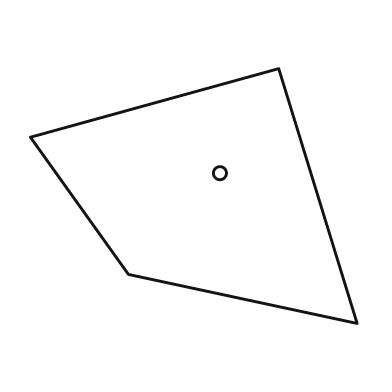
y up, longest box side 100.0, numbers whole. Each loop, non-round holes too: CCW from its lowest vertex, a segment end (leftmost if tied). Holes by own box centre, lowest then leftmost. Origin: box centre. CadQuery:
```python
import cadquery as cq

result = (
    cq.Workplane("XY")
    .moveTo(50.0, -39.0)
    .lineTo(26.0, 39.0)
    .lineTo(-50.0, 18.0)
    .lineTo(-20.0, -24.0)
    .close()
    .moveTo(8.0, 7.0)
    .circle(2.0)
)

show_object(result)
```